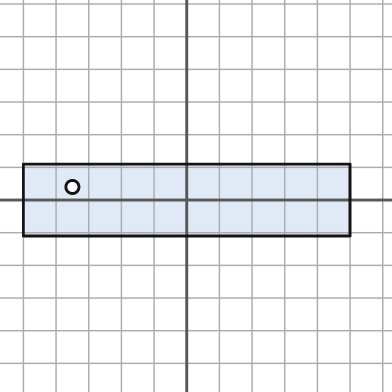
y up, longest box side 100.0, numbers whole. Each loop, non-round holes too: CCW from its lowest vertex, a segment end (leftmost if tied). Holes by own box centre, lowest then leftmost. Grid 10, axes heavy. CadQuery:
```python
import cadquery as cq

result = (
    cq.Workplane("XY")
    .moveTo(-50.0, -11.0)
    .lineTo(50.0, -11.0)
    .lineTo(50.0, 11.0)
    .lineTo(-50.0, 11.0)
    .close()
    .moveTo(-35.0, 4.0)
    .circle(2.0)
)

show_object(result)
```